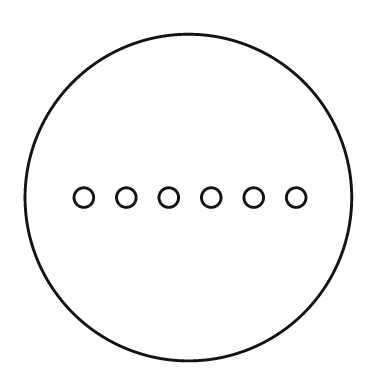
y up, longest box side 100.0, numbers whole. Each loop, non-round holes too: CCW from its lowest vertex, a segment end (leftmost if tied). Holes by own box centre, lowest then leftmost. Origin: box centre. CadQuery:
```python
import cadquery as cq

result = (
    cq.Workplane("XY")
    .moveTo(0.0, 0.0)
    .circle(50.0)
    .moveTo(-32.0, 0.0)
    .circle(3.0)
    .moveTo(-19.0, 0.0)
    .circle(3.0)
    .moveTo(-6.0, 0.0)
    .circle(3.0)
    .moveTo(7.0, 0.0)
    .circle(3.0)
    .moveTo(20.0, 0.0)
    .circle(3.0)
    .moveTo(33.0, 0.0)
    .circle(3.0)
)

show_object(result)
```